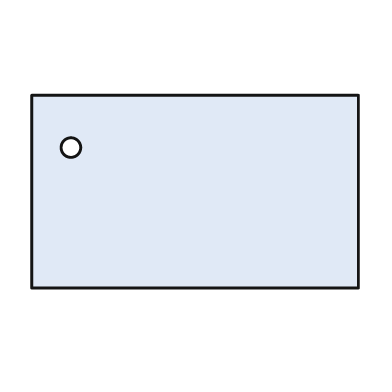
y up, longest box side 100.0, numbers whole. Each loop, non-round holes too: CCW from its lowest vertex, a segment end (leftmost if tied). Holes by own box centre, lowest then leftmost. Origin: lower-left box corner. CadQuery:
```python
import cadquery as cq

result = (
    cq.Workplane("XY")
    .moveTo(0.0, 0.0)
    .lineTo(100.0, 0.0)
    .lineTo(100.0, 59.0)
    .lineTo(0.0, 59.0)
    .close()
    .moveTo(12.0, 43.0)
    .circle(3.0)
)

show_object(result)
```